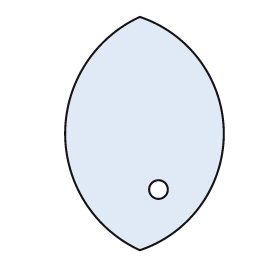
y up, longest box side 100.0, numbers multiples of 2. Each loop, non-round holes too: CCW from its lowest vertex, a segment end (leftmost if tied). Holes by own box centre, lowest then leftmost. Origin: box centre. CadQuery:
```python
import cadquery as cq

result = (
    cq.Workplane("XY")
    .moveTo(-2.0, -50.0)
    .threePointArc((34.0, 0.0), (-2.0, 50.0))
    .threePointArc((-34.0, 0.0), (-2.0, -50.0))
    .close()
    .moveTo(6.0, -24.0)
    .circle(4.0)
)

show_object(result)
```